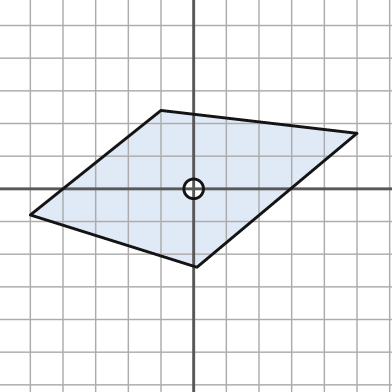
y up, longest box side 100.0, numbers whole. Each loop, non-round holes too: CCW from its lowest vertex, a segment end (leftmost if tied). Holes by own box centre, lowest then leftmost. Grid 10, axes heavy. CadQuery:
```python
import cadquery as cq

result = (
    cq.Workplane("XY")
    .moveTo(1.0, -24.0)
    .lineTo(50.0, 17.0)
    .lineTo(-10.0, 24.0)
    .lineTo(-50.0, -8.0)
    .close()
    .moveTo(0.0, 0.0)
    .circle(3.0)
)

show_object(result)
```